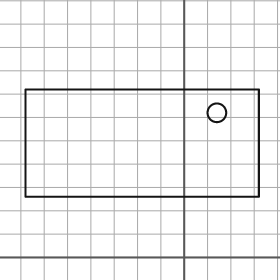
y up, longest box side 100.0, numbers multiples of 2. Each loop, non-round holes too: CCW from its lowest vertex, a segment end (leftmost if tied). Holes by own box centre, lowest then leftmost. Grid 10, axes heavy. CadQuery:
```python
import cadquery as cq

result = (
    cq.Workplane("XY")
    .moveTo(-68.0, 26.0)
    .lineTo(32.0, 26.0)
    .lineTo(32.0, 72.0)
    .lineTo(-68.0, 72.0)
    .close()
    .moveTo(14.0, 62.0)
    .circle(4.0)
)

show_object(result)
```